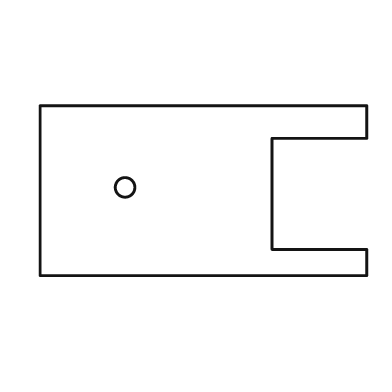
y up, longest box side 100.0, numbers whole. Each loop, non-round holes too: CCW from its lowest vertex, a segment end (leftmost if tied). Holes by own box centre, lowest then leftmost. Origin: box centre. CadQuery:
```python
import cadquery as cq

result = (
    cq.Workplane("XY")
    .moveTo(-50.0, -26.0)
    .lineTo(50.0, -26.0)
    .lineTo(50.0, -18.0)
    .lineTo(21.0, -18.0)
    .lineTo(21.0, 16.0)
    .lineTo(50.0, 16.0)
    .lineTo(50.0, 26.0)
    .lineTo(-50.0, 26.0)
    .close()
    .moveTo(-24.0, 1.0)
    .circle(3.0)
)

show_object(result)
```